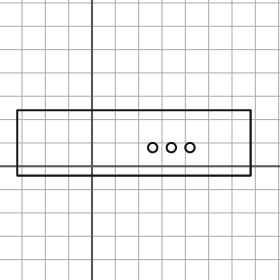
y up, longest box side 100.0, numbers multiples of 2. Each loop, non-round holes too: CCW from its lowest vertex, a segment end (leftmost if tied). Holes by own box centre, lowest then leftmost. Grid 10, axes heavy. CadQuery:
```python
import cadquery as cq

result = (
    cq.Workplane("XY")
    .moveTo(-32.0, -4.0)
    .lineTo(68.0, -4.0)
    .lineTo(68.0, 24.0)
    .lineTo(-32.0, 24.0)
    .close()
    .moveTo(26.0, 8.0)
    .circle(2.0)
    .moveTo(34.0, 8.0)
    .circle(2.0)
    .moveTo(42.0, 8.0)
    .circle(2.0)
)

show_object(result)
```